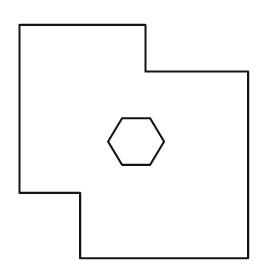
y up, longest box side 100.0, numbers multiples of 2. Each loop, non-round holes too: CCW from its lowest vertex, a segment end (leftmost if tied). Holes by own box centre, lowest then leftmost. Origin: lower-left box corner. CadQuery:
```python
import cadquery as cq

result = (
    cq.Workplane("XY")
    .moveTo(26.0, 0.0)
    .lineTo(98.0, 0.0)
    .lineTo(98.0, 80.0)
    .lineTo(54.0, 80.0)
    .lineTo(54.0, 100.0)
    .lineTo(0.0, 100.0)
    .lineTo(0.0, 28.0)
    .lineTo(26.0, 28.0)
    .close()
    .moveTo(44.0, 40.0)
    .lineTo(56.0, 40.0)
    .lineTo(62.0, 50.0)
    .lineTo(56.0, 60.0)
    .lineTo(44.0, 60.0)
    .lineTo(38.0, 50.0)
    .close()
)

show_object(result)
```